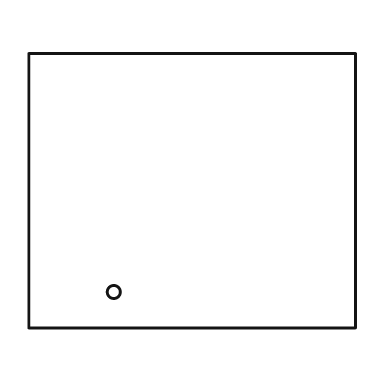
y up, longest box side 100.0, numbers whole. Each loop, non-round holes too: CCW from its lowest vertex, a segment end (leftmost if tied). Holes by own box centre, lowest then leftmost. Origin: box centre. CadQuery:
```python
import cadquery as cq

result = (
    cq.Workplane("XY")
    .moveTo(-50.0, -42.0)
    .lineTo(50.0, -42.0)
    .lineTo(50.0, 42.0)
    .lineTo(-50.0, 42.0)
    .close()
    .moveTo(-24.0, -31.0)
    .circle(2.0)
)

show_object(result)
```